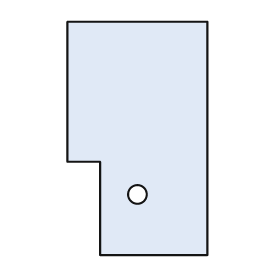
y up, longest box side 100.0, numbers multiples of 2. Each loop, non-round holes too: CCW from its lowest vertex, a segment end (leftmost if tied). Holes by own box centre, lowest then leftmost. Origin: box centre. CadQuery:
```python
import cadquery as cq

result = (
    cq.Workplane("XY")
    .moveTo(-16.0, -50.0)
    .lineTo(30.0, -50.0)
    .lineTo(30.0, 50.0)
    .lineTo(-30.0, 50.0)
    .lineTo(-30.0, -10.0)
    .lineTo(-16.0, -10.0)
    .close()
    .moveTo(0.0, -24.0)
    .circle(4.0)
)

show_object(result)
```